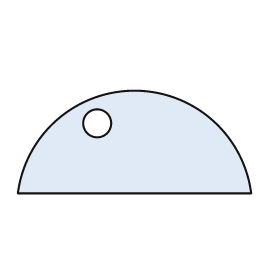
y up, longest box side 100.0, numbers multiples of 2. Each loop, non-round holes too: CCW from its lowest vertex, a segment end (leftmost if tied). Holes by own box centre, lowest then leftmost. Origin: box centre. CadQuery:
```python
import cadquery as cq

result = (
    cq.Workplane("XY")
    .moveTo(-50.0, -22.0)
    .lineTo(50.0, -22.0)
    .threePointArc((0.0, 22.0), (-50.0, -22.0))
    .close()
    .moveTo(-16.0, 8.0)
    .circle(6.0)
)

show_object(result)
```